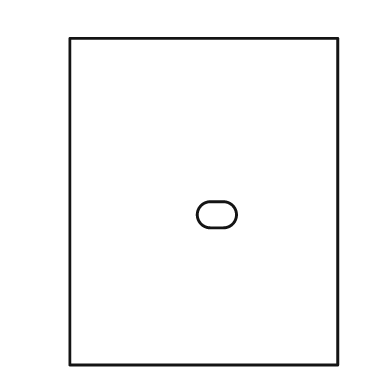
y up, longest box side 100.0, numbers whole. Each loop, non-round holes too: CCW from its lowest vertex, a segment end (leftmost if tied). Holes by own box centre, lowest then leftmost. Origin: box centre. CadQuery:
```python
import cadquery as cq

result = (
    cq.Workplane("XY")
    .moveTo(-41.0, -50.0)
    .lineTo(41.0, -50.0)
    .lineTo(41.0, 50.0)
    .lineTo(-41.0, 50.0)
    .close()
    .moveTo(2.0, -8.0)
    .lineTo(6.0, -8.0)
    .threePointArc((10.0, -4.0), (6.0, 0.0))
    .lineTo(2.0, 0.0)
    .threePointArc((-2.0, -4.0), (2.0, -8.0))
    .close()
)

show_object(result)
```